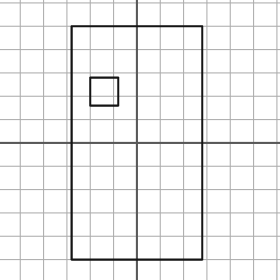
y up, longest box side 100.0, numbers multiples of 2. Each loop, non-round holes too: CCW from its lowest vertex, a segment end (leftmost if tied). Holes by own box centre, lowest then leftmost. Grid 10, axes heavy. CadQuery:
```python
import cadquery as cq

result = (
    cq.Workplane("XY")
    .moveTo(-28.0, -50.0)
    .lineTo(28.0, -50.0)
    .lineTo(28.0, 50.0)
    .lineTo(-28.0, 50.0)
    .close()
    .moveTo(-20.0, 16.0)
    .lineTo(-8.0, 16.0)
    .lineTo(-8.0, 28.0)
    .lineTo(-20.0, 28.0)
    .close()
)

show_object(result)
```